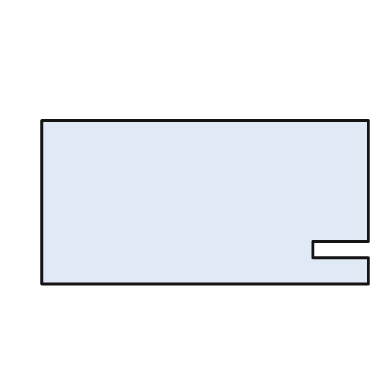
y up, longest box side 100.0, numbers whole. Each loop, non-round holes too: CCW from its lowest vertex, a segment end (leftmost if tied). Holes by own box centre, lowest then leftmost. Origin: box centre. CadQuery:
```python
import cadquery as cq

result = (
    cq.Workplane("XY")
    .moveTo(-50.0, -25.0)
    .lineTo(50.0, -25.0)
    .lineTo(50.0, -17.0)
    .lineTo(33.0, -17.0)
    .lineTo(33.0, -12.0)
    .lineTo(50.0, -12.0)
    .lineTo(50.0, 25.0)
    .lineTo(-50.0, 25.0)
    .close()
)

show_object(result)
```